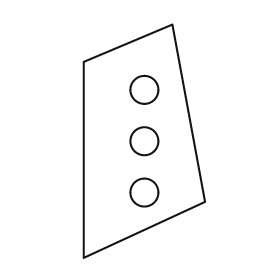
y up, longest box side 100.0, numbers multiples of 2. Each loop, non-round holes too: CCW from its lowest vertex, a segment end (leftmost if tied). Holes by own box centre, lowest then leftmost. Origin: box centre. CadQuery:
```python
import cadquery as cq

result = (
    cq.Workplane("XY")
    .moveTo(-26.0, -50.0)
    .lineTo(26.0, -26.0)
    .lineTo(12.0, 50.0)
    .lineTo(-26.0, 34.0)
    .close()
    .moveTo(0.0, -22.0)
    .circle(6.0)
    .moveTo(0.0, 0.0)
    .circle(6.0)
    .moveTo(0.0, 22.0)
    .circle(6.0)
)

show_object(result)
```